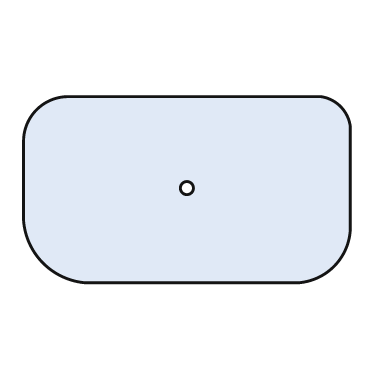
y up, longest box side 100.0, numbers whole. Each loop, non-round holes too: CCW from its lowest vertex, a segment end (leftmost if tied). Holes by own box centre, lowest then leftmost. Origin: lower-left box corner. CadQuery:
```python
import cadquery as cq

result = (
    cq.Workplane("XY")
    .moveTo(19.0, 0.0)
    .lineTo(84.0, 0.0)
    .threePointArc((95.0, 5.0), (100.0, 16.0))
    .lineTo(100.0, 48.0)
    .threePointArc((97.0, 54.0), (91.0, 57.0))
    .lineTo(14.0, 57.0)
    .threePointArc((4.0, 53.0), (0.0, 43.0))
    .lineTo(0.0, 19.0)
    .threePointArc((6.0, 6.0), (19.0, 0.0))
    .close()
    .moveTo(50.0, 29.0)
    .circle(2.0)
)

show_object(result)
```